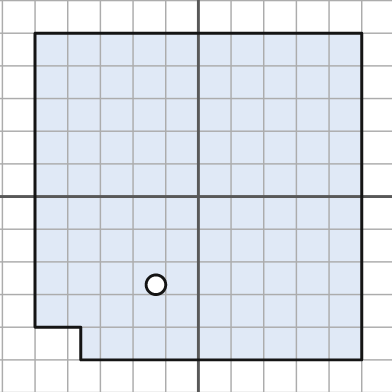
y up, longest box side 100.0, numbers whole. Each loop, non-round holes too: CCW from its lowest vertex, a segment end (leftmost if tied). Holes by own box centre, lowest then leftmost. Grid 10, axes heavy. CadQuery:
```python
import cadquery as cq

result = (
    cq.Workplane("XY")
    .moveTo(-36.0, -50.0)
    .lineTo(50.0, -50.0)
    .lineTo(50.0, 50.0)
    .lineTo(-50.0, 50.0)
    .lineTo(-50.0, -40.0)
    .lineTo(-36.0, -40.0)
    .close()
    .moveTo(-13.0, -27.0)
    .circle(3.0)
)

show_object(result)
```